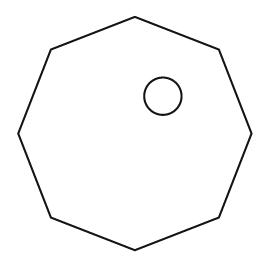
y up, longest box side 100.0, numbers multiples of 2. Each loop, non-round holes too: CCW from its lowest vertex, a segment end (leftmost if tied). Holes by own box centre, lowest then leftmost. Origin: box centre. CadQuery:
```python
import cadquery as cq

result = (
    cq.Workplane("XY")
    .moveTo(0.0, -50.0)
    .lineTo(36.0, -36.0)
    .lineTo(50.0, 0.0)
    .lineTo(36.0, 36.0)
    .lineTo(0.0, 50.0)
    .lineTo(-36.0, 36.0)
    .lineTo(-50.0, 0.0)
    .lineTo(-36.0, -36.0)
    .close()
    .moveTo(12.0, 16.0)
    .circle(8.0)
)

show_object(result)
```